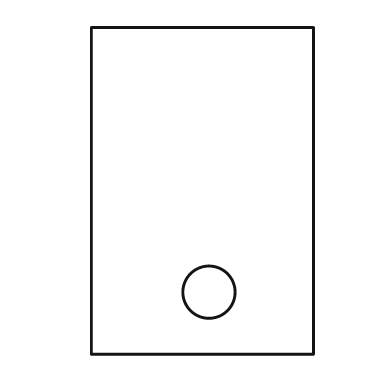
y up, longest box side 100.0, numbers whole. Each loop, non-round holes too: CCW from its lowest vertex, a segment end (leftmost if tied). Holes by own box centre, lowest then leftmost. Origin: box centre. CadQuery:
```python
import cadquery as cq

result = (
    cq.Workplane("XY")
    .moveTo(-34.0, -50.0)
    .lineTo(34.0, -50.0)
    .lineTo(34.0, 50.0)
    .lineTo(-34.0, 50.0)
    .close()
    .moveTo(2.0, -31.0)
    .circle(8.0)
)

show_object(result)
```